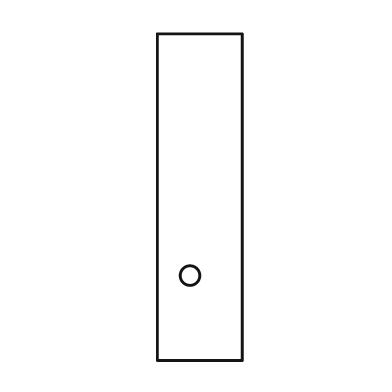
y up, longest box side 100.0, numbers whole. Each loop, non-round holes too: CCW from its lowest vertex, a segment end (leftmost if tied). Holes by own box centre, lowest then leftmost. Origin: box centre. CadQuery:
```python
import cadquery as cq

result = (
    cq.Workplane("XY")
    .moveTo(-13.0, -50.0)
    .lineTo(13.0, -50.0)
    .lineTo(13.0, 50.0)
    .lineTo(-13.0, 50.0)
    .close()
    .moveTo(-3.0, -24.0)
    .circle(3.0)
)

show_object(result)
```